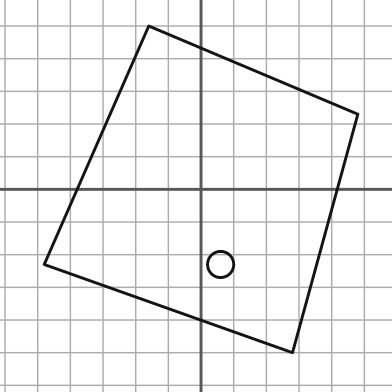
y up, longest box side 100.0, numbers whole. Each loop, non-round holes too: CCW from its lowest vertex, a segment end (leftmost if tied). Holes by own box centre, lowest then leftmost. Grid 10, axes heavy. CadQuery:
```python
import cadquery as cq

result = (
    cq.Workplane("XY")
    .moveTo(28.0, -50.0)
    .lineTo(48.0, 23.0)
    .lineTo(-16.0, 50.0)
    .lineTo(-48.0, -23.0)
    .close()
    .moveTo(6.0, -23.0)
    .circle(4.0)
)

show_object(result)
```